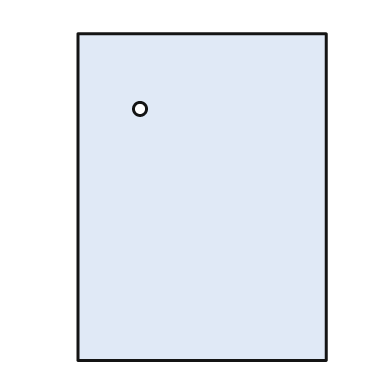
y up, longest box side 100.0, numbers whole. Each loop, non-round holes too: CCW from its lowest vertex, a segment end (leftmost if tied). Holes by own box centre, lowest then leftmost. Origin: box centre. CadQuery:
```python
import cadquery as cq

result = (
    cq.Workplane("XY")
    .moveTo(-38.0, -50.0)
    .lineTo(38.0, -50.0)
    .lineTo(38.0, 50.0)
    .lineTo(-38.0, 50.0)
    .close()
    .moveTo(-19.0, 27.0)
    .circle(2.0)
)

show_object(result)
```